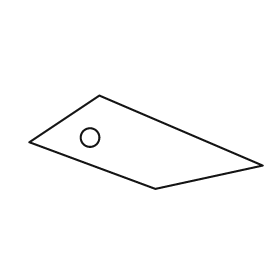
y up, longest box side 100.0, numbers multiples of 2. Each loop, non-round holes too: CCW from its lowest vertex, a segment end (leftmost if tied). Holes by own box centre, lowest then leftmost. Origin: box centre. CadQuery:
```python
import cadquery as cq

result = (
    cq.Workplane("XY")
    .moveTo(4.0, -20.0)
    .lineTo(50.0, -10.0)
    .lineTo(-20.0, 20.0)
    .lineTo(-50.0, 0.0)
    .close()
    .moveTo(-24.0, 2.0)
    .circle(4.0)
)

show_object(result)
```